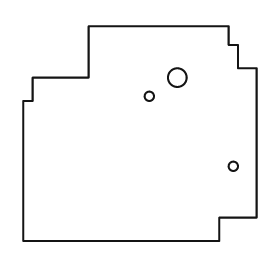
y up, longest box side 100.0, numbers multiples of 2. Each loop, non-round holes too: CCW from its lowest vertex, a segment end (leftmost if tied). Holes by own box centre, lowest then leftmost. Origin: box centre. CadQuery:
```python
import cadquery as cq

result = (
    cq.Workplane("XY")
    .moveTo(-50.0, -46.0)
    .lineTo(34.0, -46.0)
    .lineTo(34.0, -36.0)
    .lineTo(50.0, -36.0)
    .lineTo(50.0, 28.0)
    .lineTo(42.0, 28.0)
    .lineTo(42.0, 38.0)
    .lineTo(38.0, 38.0)
    .lineTo(38.0, 46.0)
    .lineTo(-22.0, 46.0)
    .lineTo(-22.0, 24.0)
    .lineTo(-46.0, 24.0)
    .lineTo(-46.0, 14.0)
    .lineTo(-50.0, 14.0)
    .close()
    .moveTo(40.0, -14.0)
    .circle(2.0)
    .moveTo(4.0, 16.0)
    .circle(2.0)
    .moveTo(16.0, 24.0)
    .circle(4.0)
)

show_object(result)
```